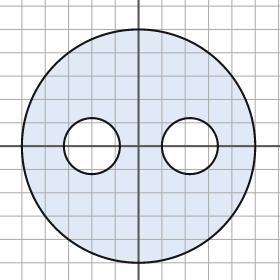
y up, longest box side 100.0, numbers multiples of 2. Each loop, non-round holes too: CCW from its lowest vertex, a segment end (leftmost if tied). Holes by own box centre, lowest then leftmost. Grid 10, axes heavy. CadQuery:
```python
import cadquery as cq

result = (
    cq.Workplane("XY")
    .moveTo(0.0, 0.0)
    .circle(50.0)
    .moveTo(-20.0, 0.0)
    .circle(12.0)
    .moveTo(22.0, 0.0)
    .circle(12.0)
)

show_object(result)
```